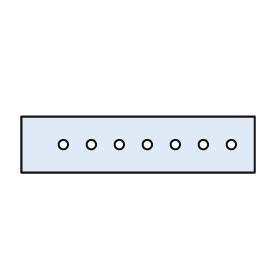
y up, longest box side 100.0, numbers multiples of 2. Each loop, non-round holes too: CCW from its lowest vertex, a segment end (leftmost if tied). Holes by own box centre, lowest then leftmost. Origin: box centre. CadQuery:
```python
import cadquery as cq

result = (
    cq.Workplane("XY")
    .moveTo(-50.0, -12.0)
    .lineTo(50.0, -12.0)
    .lineTo(50.0, 12.0)
    .lineTo(-50.0, 12.0)
    .close()
    .moveTo(-32.0, 0.0)
    .circle(2.0)
    .moveTo(-20.0, 0.0)
    .circle(2.0)
    .moveTo(-8.0, 0.0)
    .circle(2.0)
    .moveTo(4.0, 0.0)
    .circle(2.0)
    .moveTo(16.0, 0.0)
    .circle(2.0)
    .moveTo(28.0, 0.0)
    .circle(2.0)
    .moveTo(40.0, 0.0)
    .circle(2.0)
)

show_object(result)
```